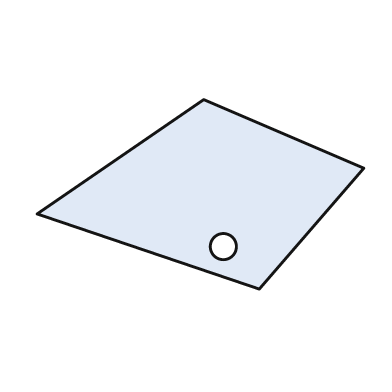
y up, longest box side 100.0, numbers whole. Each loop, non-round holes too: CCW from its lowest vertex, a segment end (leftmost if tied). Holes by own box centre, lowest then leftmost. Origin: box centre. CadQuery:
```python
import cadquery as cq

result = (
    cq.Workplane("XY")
    .moveTo(18.0, -29.0)
    .lineTo(50.0, 8.0)
    .lineTo(1.0, 29.0)
    .lineTo(-50.0, -6.0)
    .close()
    .moveTo(7.0, -16.0)
    .circle(4.0)
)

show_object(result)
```